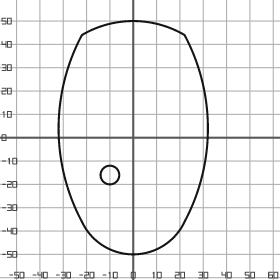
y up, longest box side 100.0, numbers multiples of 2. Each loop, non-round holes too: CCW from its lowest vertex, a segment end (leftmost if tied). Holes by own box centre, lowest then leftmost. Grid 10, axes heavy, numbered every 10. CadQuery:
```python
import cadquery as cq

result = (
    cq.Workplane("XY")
    .moveTo(-22.0, -36.0)
    .threePointArc((0.0, -50.0), (22.0, -36.0))
    .threePointArc((32.0, 4.0), (22.0, 44.0))
    .threePointArc((0.0, 50.0), (-22.0, 44.0))
    .threePointArc((-32.0, 4.0), (-22.0, -36.0))
    .close()
    .moveTo(-10.0, -16.0)
    .circle(4.0)
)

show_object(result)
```